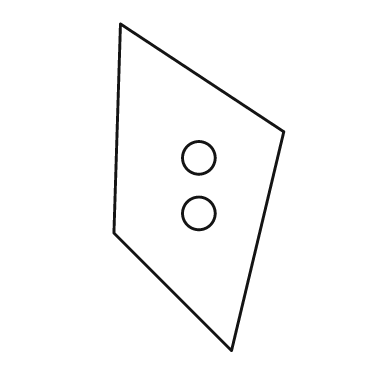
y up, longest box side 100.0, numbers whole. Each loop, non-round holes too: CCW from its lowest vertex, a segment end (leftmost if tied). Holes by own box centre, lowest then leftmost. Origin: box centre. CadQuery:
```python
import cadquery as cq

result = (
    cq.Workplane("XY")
    .moveTo(10.0, -50.0)
    .lineTo(26.0, 17.0)
    .lineTo(-24.0, 50.0)
    .lineTo(-26.0, -14.0)
    .close()
    .moveTo(0.0, -8.0)
    .circle(5.0)
    .moveTo(0.0, 9.0)
    .circle(5.0)
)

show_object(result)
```